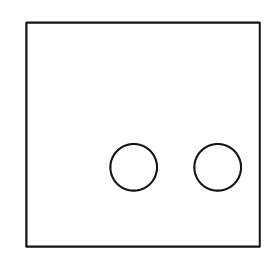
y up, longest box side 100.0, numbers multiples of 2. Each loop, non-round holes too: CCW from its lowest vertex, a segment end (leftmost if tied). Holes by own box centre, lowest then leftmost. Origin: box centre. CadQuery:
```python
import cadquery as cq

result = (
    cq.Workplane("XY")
    .moveTo(-50.0, -48.0)
    .lineTo(50.0, -48.0)
    .lineTo(50.0, 48.0)
    .lineTo(-50.0, 48.0)
    .close()
    .moveTo(-4.0, -14.0)
    .circle(10.0)
    .moveTo(32.0, -14.0)
    .circle(10.0)
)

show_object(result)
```